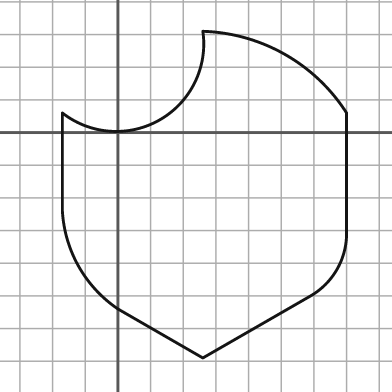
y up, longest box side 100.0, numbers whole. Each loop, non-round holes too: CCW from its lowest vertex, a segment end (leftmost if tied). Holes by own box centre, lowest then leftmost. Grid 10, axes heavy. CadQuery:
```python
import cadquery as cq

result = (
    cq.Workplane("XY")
    .moveTo(26.0, -69.0)
    .lineTo(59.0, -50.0)
    .threePointArc((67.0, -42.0), (70.0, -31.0))
    .lineTo(70.0, 6.0)
    .threePointArc((51.0, 24.0), (26.0, 31.0))
    .threePointArc((13.0, 4.0), (-17.0, 6.0))
    .lineTo(-17.0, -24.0)
    .threePointArc((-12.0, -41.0), (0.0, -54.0))
    .close()
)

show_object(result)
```